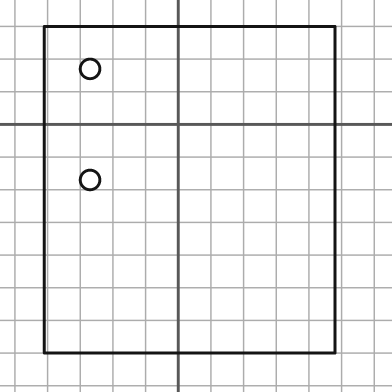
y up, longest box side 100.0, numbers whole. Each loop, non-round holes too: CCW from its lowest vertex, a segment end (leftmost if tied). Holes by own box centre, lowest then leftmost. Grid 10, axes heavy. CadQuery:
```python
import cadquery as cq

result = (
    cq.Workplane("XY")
    .moveTo(-41.0, -70.0)
    .lineTo(48.0, -70.0)
    .lineTo(48.0, 30.0)
    .lineTo(-41.0, 30.0)
    .close()
    .moveTo(-27.0, -17.0)
    .circle(3.0)
    .moveTo(-27.0, 17.0)
    .circle(3.0)
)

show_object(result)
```